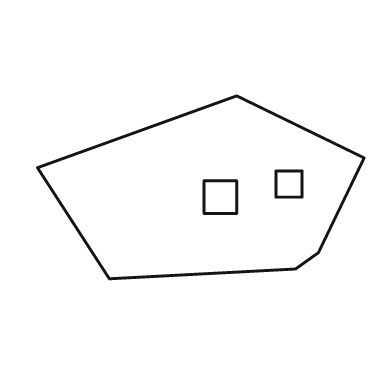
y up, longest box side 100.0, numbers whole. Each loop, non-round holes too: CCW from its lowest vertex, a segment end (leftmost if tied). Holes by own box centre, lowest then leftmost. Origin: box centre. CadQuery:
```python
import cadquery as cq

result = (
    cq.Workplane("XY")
    .moveTo(-28.0, -28.0)
    .lineTo(29.0, -25.0)
    .lineTo(36.0, -20.0)
    .lineTo(50.0, 9.0)
    .lineTo(11.0, 28.0)
    .lineTo(-50.0, 6.0)
    .close()
    .moveTo(1.0, -8.0)
    .lineTo(11.0, -8.0)
    .lineTo(11.0, 2.0)
    .lineTo(1.0, 2.0)
    .close()
    .moveTo(23.0, -3.0)
    .lineTo(31.0, -3.0)
    .lineTo(31.0, 5.0)
    .lineTo(23.0, 5.0)
    .close()
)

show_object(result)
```